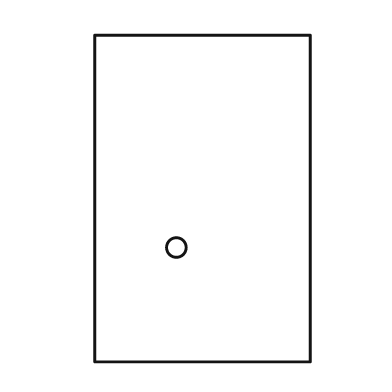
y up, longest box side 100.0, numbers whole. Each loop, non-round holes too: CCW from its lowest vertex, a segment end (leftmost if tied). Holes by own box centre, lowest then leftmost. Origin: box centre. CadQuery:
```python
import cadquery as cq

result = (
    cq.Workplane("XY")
    .moveTo(-33.0, -50.0)
    .lineTo(33.0, -50.0)
    .lineTo(33.0, 50.0)
    .lineTo(-33.0, 50.0)
    .close()
    .moveTo(-8.0, -15.0)
    .circle(3.0)
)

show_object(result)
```